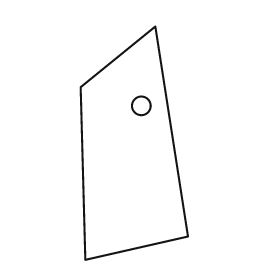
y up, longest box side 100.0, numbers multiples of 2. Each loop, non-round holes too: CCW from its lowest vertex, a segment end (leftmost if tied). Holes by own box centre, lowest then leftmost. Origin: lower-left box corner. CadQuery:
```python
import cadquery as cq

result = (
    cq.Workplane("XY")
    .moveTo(2.0, 0.0)
    .lineTo(46.0, 10.0)
    .lineTo(32.0, 100.0)
    .lineTo(0.0, 74.0)
    .close()
    .moveTo(26.0, 66.0)
    .circle(4.0)
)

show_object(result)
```